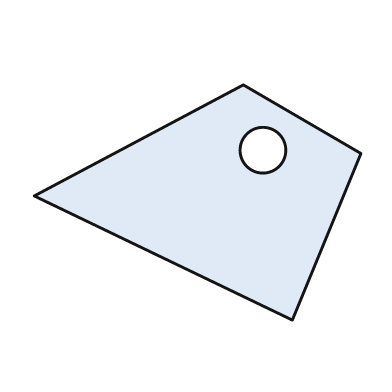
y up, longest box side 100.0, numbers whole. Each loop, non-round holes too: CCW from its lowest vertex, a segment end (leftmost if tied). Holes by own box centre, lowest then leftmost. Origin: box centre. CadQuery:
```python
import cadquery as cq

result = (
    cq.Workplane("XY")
    .moveTo(29.0, -36.0)
    .lineTo(50.0, 15.0)
    .lineTo(14.0, 36.0)
    .lineTo(-50.0, 2.0)
    .close()
    .moveTo(20.0, 16.0)
    .circle(7.0)
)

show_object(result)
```